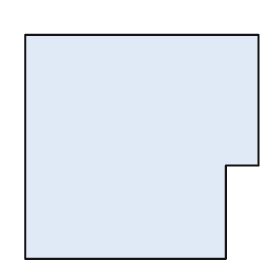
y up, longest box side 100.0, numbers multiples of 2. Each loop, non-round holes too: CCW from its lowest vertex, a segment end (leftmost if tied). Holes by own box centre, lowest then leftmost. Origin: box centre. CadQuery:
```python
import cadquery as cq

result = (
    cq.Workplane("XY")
    .moveTo(-50.0, -48.0)
    .lineTo(36.0, -48.0)
    .lineTo(36.0, -8.0)
    .lineTo(50.0, -8.0)
    .lineTo(50.0, 48.0)
    .lineTo(-50.0, 48.0)
    .close()
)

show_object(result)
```